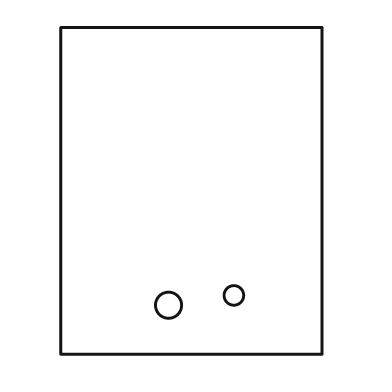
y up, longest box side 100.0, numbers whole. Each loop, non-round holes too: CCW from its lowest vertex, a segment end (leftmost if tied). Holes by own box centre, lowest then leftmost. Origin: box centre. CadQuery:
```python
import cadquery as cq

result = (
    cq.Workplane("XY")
    .moveTo(-40.0, -50.0)
    .lineTo(40.0, -50.0)
    .lineTo(40.0, 50.0)
    .lineTo(-40.0, 50.0)
    .close()
    .moveTo(-7.0, -35.0)
    .circle(4.0)
    .moveTo(13.0, -32.0)
    .circle(3.0)
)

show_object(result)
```